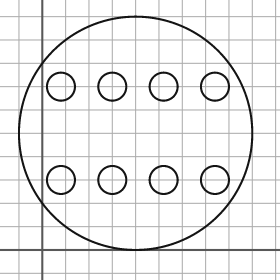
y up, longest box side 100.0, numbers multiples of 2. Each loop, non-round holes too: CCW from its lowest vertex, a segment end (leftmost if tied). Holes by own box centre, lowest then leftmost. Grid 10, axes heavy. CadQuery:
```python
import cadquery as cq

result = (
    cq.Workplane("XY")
    .moveTo(40.0, 50.0)
    .circle(50.0)
    .moveTo(8.0, 30.0)
    .circle(6.0)
    .moveTo(30.0, 30.0)
    .circle(6.0)
    .moveTo(52.0, 30.0)
    .circle(6.0)
    .moveTo(74.0, 30.0)
    .circle(6.0)
    .moveTo(8.0, 70.0)
    .circle(6.0)
    .moveTo(30.0, 70.0)
    .circle(6.0)
    .moveTo(52.0, 70.0)
    .circle(6.0)
    .moveTo(74.0, 70.0)
    .circle(6.0)
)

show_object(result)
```